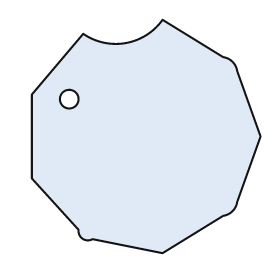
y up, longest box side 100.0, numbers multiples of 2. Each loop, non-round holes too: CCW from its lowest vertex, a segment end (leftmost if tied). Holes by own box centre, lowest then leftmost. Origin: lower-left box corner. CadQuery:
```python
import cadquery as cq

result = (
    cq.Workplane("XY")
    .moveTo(56.0, 0.0)
    .lineTo(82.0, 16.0)
    .threePointArc((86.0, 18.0), (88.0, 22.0))
    .lineTo(98.0, 50.0)
    .lineTo(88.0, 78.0)
    .threePointArc((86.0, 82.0), (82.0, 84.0))
    .lineTo(56.0, 100.0)
    .threePointArc((40.0, 90.0), (22.0, 94.0))
    .lineTo(0.0, 68.0)
    .lineTo(0.0, 32.0)
    .lineTo(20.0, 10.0)
    .threePointArc((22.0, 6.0), (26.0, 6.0))
    .close()
    .moveTo(16.0, 66.0)
    .circle(4.0)
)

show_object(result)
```